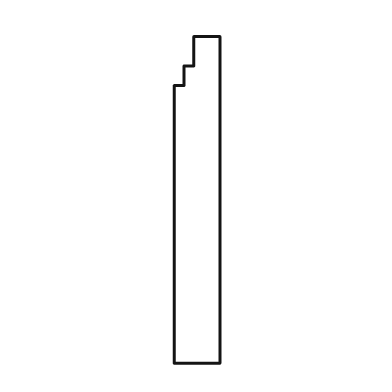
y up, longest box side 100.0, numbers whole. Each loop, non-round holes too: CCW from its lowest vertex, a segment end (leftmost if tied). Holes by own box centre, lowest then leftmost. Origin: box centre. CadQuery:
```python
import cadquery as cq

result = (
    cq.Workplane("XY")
    .moveTo(-7.0, -50.0)
    .lineTo(7.0, -50.0)
    .lineTo(7.0, 50.0)
    .lineTo(-1.0, 50.0)
    .lineTo(-1.0, 41.0)
    .lineTo(-4.0, 41.0)
    .lineTo(-4.0, 35.0)
    .lineTo(-7.0, 35.0)
    .close()
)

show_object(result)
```